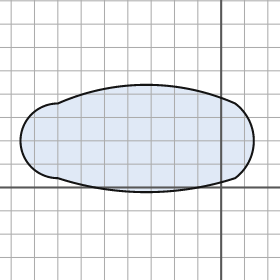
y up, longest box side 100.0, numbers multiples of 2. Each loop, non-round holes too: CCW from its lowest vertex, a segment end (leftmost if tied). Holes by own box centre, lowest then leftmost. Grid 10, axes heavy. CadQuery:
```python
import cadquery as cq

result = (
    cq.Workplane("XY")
    .moveTo(-70.0, 4.0)
    .threePointArc((-32.0, -2.0), (6.0, 4.0))
    .threePointArc((14.0, 20.0), (6.0, 36.0))
    .threePointArc((-32.0, 44.0), (-70.0, 36.0))
    .threePointArc((-86.0, 20.0), (-70.0, 4.0))
    .close()
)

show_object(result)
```